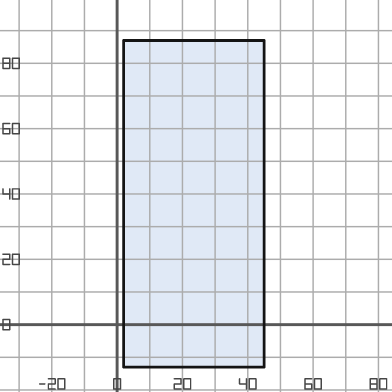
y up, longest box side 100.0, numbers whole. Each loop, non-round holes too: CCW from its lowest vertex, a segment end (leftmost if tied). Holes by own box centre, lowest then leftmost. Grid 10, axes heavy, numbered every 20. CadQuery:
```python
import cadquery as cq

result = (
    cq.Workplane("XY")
    .moveTo(2.0, -13.0)
    .lineTo(45.0, -13.0)
    .lineTo(45.0, 87.0)
    .lineTo(2.0, 87.0)
    .close()
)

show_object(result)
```